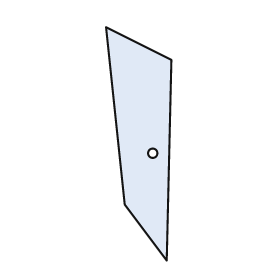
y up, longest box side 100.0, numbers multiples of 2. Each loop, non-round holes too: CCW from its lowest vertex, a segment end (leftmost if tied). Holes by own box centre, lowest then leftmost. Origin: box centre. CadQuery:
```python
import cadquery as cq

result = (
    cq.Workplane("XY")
    .moveTo(12.0, -50.0)
    .lineTo(14.0, 36.0)
    .lineTo(-14.0, 50.0)
    .lineTo(-6.0, -26.0)
    .close()
    .moveTo(6.0, -4.0)
    .circle(2.0)
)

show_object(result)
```